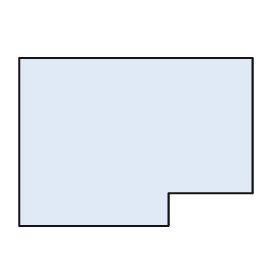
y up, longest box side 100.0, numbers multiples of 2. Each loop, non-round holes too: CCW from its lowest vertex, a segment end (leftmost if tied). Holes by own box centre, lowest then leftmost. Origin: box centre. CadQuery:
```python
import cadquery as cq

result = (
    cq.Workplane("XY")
    .moveTo(-50.0, -36.0)
    .lineTo(14.0, -36.0)
    .lineTo(14.0, -22.0)
    .lineTo(50.0, -22.0)
    .lineTo(50.0, 36.0)
    .lineTo(-50.0, 36.0)
    .close()
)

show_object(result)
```